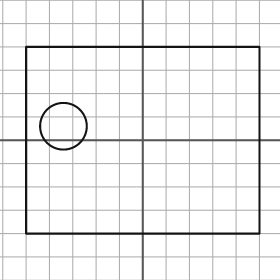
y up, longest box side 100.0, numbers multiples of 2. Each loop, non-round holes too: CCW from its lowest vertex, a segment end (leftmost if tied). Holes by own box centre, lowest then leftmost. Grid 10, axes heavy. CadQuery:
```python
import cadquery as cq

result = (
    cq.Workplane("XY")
    .moveTo(-50.0, -40.0)
    .lineTo(50.0, -40.0)
    .lineTo(50.0, 40.0)
    .lineTo(-50.0, 40.0)
    .close()
    .moveTo(-34.0, 6.0)
    .circle(10.0)
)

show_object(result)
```